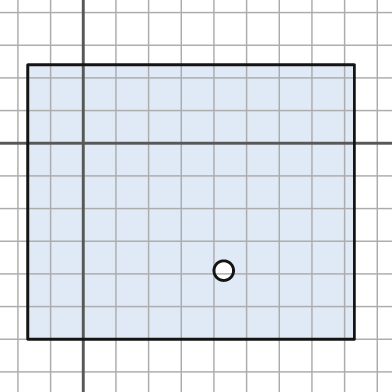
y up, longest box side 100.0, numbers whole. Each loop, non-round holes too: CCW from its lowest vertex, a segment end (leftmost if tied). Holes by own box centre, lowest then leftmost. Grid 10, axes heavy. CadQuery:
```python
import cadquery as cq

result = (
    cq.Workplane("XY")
    .moveTo(-17.0, -60.0)
    .lineTo(83.0, -60.0)
    .lineTo(83.0, 24.0)
    .lineTo(-17.0, 24.0)
    .close()
    .moveTo(43.0, -39.0)
    .circle(3.0)
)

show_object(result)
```